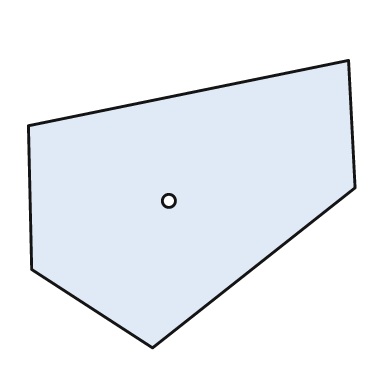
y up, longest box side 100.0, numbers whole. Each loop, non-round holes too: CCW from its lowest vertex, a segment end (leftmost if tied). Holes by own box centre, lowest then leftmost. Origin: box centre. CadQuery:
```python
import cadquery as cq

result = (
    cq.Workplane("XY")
    .moveTo(-12.0, -44.0)
    .lineTo(50.0, 5.0)
    .lineTo(48.0, 44.0)
    .lineTo(-50.0, 24.0)
    .lineTo(-49.0, -20.0)
    .close()
    .moveTo(-7.0, 1.0)
    .circle(2.0)
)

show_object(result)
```